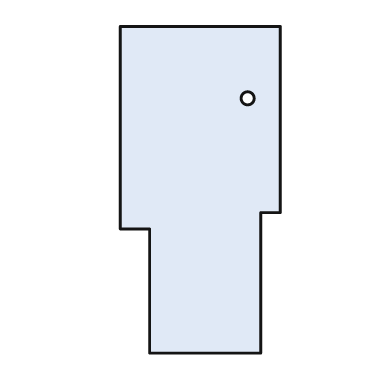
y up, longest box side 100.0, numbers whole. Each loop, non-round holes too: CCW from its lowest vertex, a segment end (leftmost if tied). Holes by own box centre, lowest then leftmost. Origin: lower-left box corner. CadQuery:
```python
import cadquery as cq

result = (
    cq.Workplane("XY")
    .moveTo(9.0, 0.0)
    .lineTo(43.0, 0.0)
    .lineTo(43.0, 43.0)
    .lineTo(49.0, 43.0)
    .lineTo(49.0, 100.0)
    .lineTo(0.0, 100.0)
    .lineTo(0.0, 38.0)
    .lineTo(9.0, 38.0)
    .close()
    .moveTo(39.0, 78.0)
    .circle(2.0)
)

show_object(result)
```